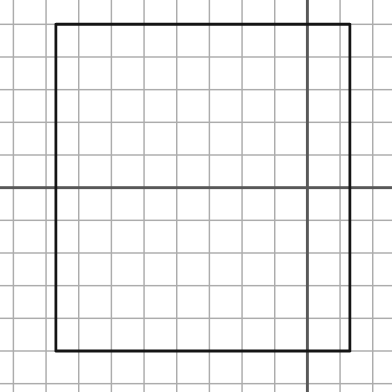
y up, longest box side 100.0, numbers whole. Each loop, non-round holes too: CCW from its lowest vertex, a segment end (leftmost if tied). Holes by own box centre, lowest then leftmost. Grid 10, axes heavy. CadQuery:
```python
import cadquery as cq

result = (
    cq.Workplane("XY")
    .moveTo(-77.0, -50.0)
    .lineTo(13.0, -50.0)
    .lineTo(13.0, 50.0)
    .lineTo(-77.0, 50.0)
    .close()
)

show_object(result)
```